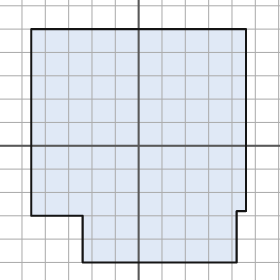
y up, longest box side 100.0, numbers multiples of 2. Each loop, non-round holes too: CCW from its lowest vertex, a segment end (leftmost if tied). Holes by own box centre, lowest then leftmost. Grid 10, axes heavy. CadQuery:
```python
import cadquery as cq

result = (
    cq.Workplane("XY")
    .moveTo(-24.0, -50.0)
    .lineTo(42.0, -50.0)
    .lineTo(42.0, -28.0)
    .lineTo(46.0, -28.0)
    .lineTo(46.0, 50.0)
    .lineTo(-46.0, 50.0)
    .lineTo(-46.0, -30.0)
    .lineTo(-24.0, -30.0)
    .close()
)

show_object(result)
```